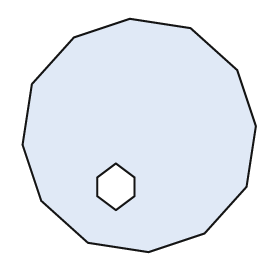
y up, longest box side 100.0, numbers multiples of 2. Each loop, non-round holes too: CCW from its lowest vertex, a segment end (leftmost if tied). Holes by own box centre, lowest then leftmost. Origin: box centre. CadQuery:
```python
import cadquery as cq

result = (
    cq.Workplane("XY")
    .moveTo(4.0, -50.0)
    .lineTo(28.0, -42.0)
    .lineTo(46.0, -22.0)
    .lineTo(50.0, 4.0)
    .lineTo(42.0, 28.0)
    .lineTo(22.0, 46.0)
    .lineTo(-4.0, 50.0)
    .lineTo(-28.0, 42.0)
    .lineTo(-46.0, 22.0)
    .lineTo(-50.0, -4.0)
    .lineTo(-42.0, -28.0)
    .lineTo(-22.0, -46.0)
    .close()
    .moveTo(-10.0, -32.0)
    .lineTo(-2.0, -26.0)
    .lineTo(-2.0, -18.0)
    .lineTo(-10.0, -12.0)
    .lineTo(-18.0, -18.0)
    .lineTo(-18.0, -26.0)
    .close()
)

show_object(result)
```